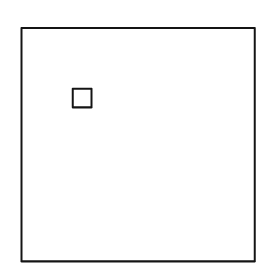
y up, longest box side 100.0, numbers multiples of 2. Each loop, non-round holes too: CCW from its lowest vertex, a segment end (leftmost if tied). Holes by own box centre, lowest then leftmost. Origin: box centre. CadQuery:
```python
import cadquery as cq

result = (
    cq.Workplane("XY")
    .moveTo(-50.0, -50.0)
    .lineTo(50.0, -50.0)
    .lineTo(50.0, 50.0)
    .lineTo(-50.0, 50.0)
    .close()
    .moveTo(-28.0, 16.0)
    .lineTo(-20.0, 16.0)
    .lineTo(-20.0, 24.0)
    .lineTo(-28.0, 24.0)
    .close()
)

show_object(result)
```